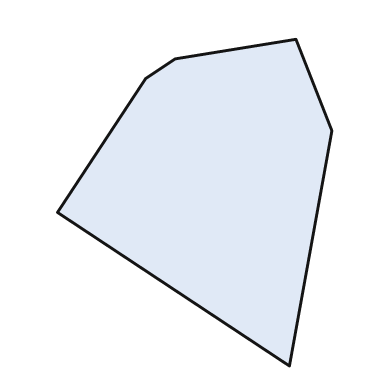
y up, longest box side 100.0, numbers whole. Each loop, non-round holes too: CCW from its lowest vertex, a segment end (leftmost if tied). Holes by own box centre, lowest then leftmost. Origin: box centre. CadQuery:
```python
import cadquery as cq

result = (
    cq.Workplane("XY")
    .moveTo(29.0, -50.0)
    .lineTo(42.0, 22.0)
    .lineTo(31.0, 50.0)
    .lineTo(-6.0, 44.0)
    .lineTo(-15.0, 38.0)
    .lineTo(-42.0, -3.0)
    .close()
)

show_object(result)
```